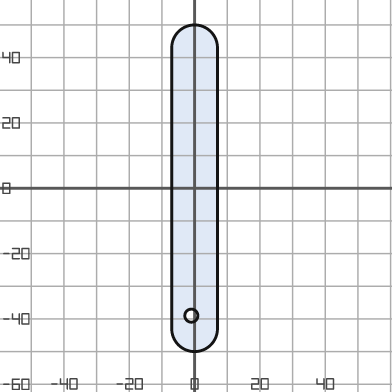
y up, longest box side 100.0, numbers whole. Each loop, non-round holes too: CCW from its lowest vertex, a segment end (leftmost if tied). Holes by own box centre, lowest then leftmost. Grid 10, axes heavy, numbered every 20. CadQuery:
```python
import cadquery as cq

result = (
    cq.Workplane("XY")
    .moveTo(-7.0, -43.0)
    .threePointArc((0.0, -50.0), (7.0, -43.0))
    .lineTo(7.0, 43.0)
    .threePointArc((0.0, 50.0), (-7.0, 43.0))
    .close()
    .moveTo(-1.0, -39.0)
    .circle(2.0)
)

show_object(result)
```